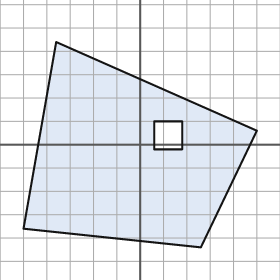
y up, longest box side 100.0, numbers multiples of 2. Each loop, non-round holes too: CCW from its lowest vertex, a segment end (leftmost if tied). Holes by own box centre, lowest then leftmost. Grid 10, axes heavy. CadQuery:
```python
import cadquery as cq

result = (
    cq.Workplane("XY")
    .moveTo(26.0, -44.0)
    .lineTo(50.0, 6.0)
    .lineTo(-36.0, 44.0)
    .lineTo(-50.0, -36.0)
    .close()
    .moveTo(6.0, -2.0)
    .lineTo(18.0, -2.0)
    .lineTo(18.0, 10.0)
    .lineTo(6.0, 10.0)
    .close()
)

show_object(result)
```